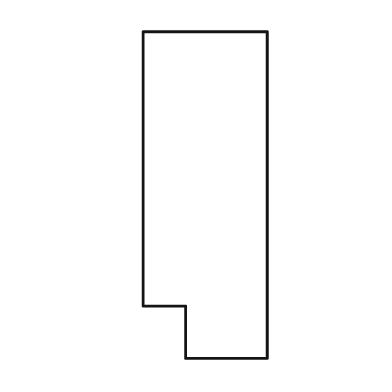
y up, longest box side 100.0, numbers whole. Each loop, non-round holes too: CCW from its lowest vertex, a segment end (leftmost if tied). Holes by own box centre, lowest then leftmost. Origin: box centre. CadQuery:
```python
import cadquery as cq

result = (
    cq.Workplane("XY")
    .moveTo(-6.0, -50.0)
    .lineTo(19.0, -50.0)
    .lineTo(19.0, 50.0)
    .lineTo(-19.0, 50.0)
    .lineTo(-19.0, -34.0)
    .lineTo(-6.0, -34.0)
    .close()
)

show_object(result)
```